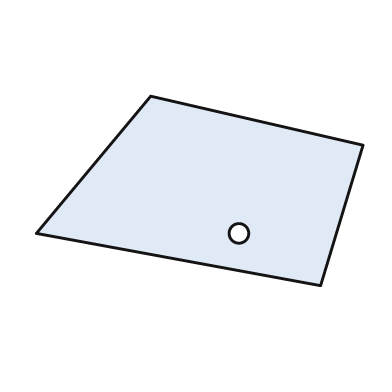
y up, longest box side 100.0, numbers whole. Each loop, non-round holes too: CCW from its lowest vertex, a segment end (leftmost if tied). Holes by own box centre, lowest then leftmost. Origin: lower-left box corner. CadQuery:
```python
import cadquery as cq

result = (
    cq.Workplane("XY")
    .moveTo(87.0, 0.0)
    .lineTo(100.0, 43.0)
    .lineTo(35.0, 58.0)
    .lineTo(0.0, 16.0)
    .close()
    .moveTo(62.0, 16.0)
    .circle(3.0)
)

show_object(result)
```